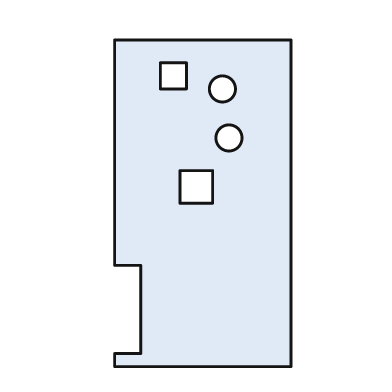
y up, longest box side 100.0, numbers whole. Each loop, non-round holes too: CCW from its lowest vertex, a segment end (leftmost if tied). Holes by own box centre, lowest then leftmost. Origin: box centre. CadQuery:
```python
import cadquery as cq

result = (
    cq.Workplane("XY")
    .moveTo(-27.0, -50.0)
    .lineTo(27.0, -50.0)
    .lineTo(27.0, 50.0)
    .lineTo(-27.0, 50.0)
    .lineTo(-27.0, -19.0)
    .lineTo(-19.0, -19.0)
    .lineTo(-19.0, -46.0)
    .lineTo(-27.0, -46.0)
    .close()
    .moveTo(-7.0, 0.0)
    .lineTo(3.0, 0.0)
    .lineTo(3.0, 10.0)
    .lineTo(-7.0, 10.0)
    .close()
    .moveTo(8.0, 20.0)
    .circle(4.0)
    .moveTo(6.0, 35.0)
    .circle(4.0)
    .moveTo(-13.0, 35.0)
    .lineTo(-5.0, 35.0)
    .lineTo(-5.0, 43.0)
    .lineTo(-13.0, 43.0)
    .close()
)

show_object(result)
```